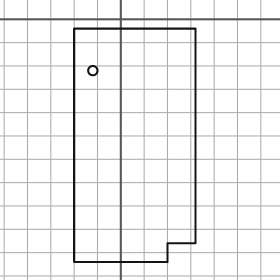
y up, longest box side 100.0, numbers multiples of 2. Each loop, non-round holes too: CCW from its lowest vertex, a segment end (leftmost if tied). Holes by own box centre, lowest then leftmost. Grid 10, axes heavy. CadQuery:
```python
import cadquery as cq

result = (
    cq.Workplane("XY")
    .moveTo(-20.0, -104.0)
    .lineTo(20.0, -104.0)
    .lineTo(20.0, -96.0)
    .lineTo(32.0, -96.0)
    .lineTo(32.0, -4.0)
    .lineTo(-20.0, -4.0)
    .close()
    .moveTo(-12.0, -22.0)
    .circle(2.0)
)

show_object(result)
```